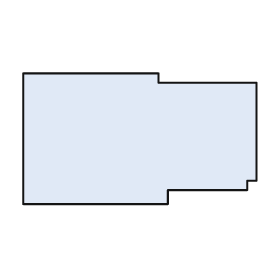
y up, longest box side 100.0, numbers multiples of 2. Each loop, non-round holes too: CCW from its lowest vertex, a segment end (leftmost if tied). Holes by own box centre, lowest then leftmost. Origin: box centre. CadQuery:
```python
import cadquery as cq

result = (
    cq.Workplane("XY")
    .moveTo(-50.0, -28.0)
    .lineTo(12.0, -28.0)
    .lineTo(12.0, -22.0)
    .lineTo(46.0, -22.0)
    .lineTo(46.0, -18.0)
    .lineTo(50.0, -18.0)
    .lineTo(50.0, 24.0)
    .lineTo(8.0, 24.0)
    .lineTo(8.0, 28.0)
    .lineTo(-50.0, 28.0)
    .close()
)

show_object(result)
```